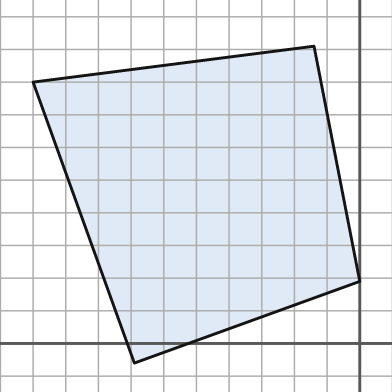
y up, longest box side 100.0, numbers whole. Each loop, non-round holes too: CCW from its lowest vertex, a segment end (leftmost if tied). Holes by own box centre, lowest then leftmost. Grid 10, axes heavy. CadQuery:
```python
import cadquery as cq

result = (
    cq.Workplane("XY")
    .moveTo(-69.0, -6.0)
    .lineTo(0.0, 19.0)
    .lineTo(-14.0, 91.0)
    .lineTo(-100.0, 80.0)
    .close()
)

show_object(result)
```